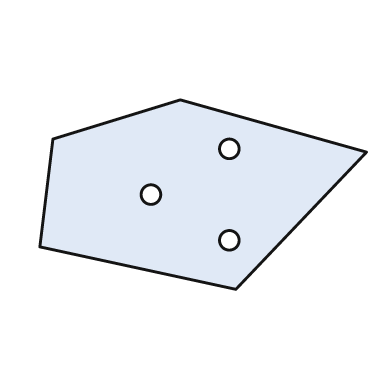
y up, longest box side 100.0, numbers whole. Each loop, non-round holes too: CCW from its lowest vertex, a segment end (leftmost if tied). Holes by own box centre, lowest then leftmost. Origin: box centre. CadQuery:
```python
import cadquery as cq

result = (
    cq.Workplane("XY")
    .moveTo(10.0, -29.0)
    .lineTo(50.0, 13.0)
    .lineTo(-7.0, 29.0)
    .lineTo(-46.0, 17.0)
    .lineTo(-50.0, -16.0)
    .close()
    .moveTo(8.0, -14.0)
    .circle(3.0)
    .moveTo(-16.0, 0.0)
    .circle(3.0)
    .moveTo(8.0, 14.0)
    .circle(3.0)
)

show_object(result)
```